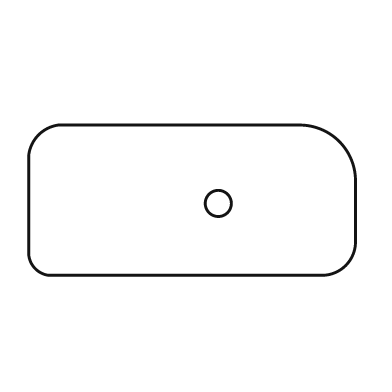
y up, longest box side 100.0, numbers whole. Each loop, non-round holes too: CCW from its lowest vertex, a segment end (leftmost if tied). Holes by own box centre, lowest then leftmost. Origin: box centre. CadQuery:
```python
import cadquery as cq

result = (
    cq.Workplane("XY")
    .moveTo(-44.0, -23.0)
    .lineTo(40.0, -23.0)
    .threePointArc((47.0, -20.0), (50.0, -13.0))
    .lineTo(50.0, 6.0)
    .threePointArc((45.0, 18.0), (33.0, 23.0))
    .lineTo(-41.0, 23.0)
    .threePointArc((-47.0, 20.0), (-50.0, 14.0))
    .lineTo(-50.0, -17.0)
    .threePointArc((-48.0, -21.0), (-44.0, -23.0))
    .close()
    .moveTo(8.0, -1.0)
    .circle(4.0)
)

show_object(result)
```